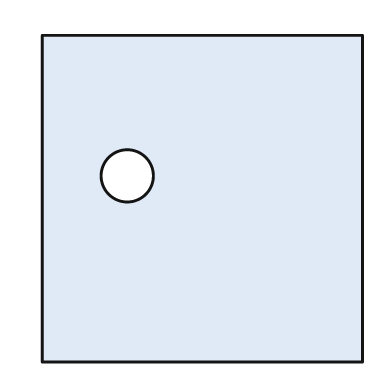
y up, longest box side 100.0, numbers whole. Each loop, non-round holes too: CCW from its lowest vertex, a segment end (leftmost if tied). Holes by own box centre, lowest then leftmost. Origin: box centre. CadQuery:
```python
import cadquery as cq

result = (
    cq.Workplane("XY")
    .moveTo(-49.0, -50.0)
    .lineTo(49.0, -50.0)
    .lineTo(49.0, 50.0)
    .lineTo(-49.0, 50.0)
    .close()
    .moveTo(-23.0, 7.0)
    .circle(8.0)
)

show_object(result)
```